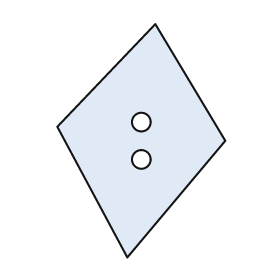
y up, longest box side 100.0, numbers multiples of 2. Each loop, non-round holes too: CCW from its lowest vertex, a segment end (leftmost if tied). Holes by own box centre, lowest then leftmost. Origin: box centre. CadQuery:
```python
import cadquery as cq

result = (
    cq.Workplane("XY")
    .moveTo(-6.0, -50.0)
    .lineTo(36.0, 0.0)
    .lineTo(6.0, 50.0)
    .lineTo(-36.0, 6.0)
    .close()
    .moveTo(0.0, -8.0)
    .circle(4.0)
    .moveTo(0.0, 8.0)
    .circle(4.0)
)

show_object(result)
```